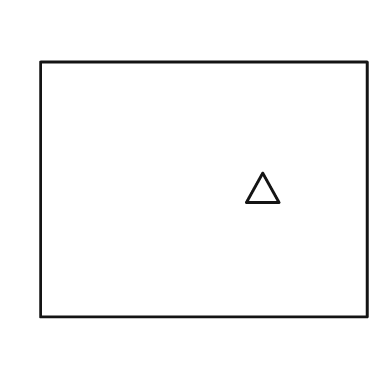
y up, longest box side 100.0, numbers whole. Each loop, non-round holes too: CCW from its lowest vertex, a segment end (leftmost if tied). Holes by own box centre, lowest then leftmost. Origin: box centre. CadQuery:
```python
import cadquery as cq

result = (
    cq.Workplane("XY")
    .moveTo(-50.0, -39.0)
    .lineTo(50.0, -39.0)
    .lineTo(50.0, 39.0)
    .lineTo(-50.0, 39.0)
    .close()
    .moveTo(13.0, -4.0)
    .lineTo(23.0, -4.0)
    .lineTo(18.0, 5.0)
    .close()
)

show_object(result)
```